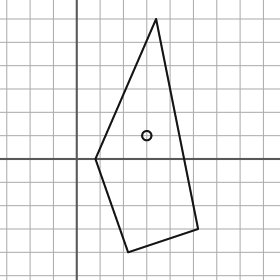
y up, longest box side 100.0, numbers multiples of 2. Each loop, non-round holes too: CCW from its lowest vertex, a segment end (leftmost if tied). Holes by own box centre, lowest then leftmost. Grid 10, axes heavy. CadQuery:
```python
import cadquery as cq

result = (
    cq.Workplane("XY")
    .moveTo(22.0, -40.0)
    .lineTo(52.0, -30.0)
    .lineTo(34.0, 60.0)
    .lineTo(8.0, 0.0)
    .close()
    .moveTo(30.0, 10.0)
    .circle(2.0)
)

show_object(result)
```